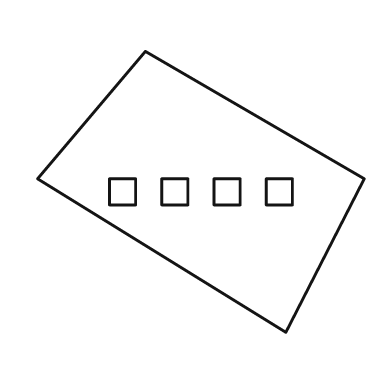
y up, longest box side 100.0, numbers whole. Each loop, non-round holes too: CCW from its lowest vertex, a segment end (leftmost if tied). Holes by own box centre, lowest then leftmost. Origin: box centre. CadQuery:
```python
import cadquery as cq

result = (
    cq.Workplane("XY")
    .moveTo(26.0, -43.0)
    .lineTo(50.0, 4.0)
    .lineTo(-17.0, 43.0)
    .lineTo(-50.0, 4.0)
    .close()
    .moveTo(-28.0, -4.0)
    .lineTo(-20.0, -4.0)
    .lineTo(-20.0, 4.0)
    .lineTo(-28.0, 4.0)
    .close()
    .moveTo(-12.0, -4.0)
    .lineTo(-4.0, -4.0)
    .lineTo(-4.0, 4.0)
    .lineTo(-12.0, 4.0)
    .close()
    .moveTo(4.0, -4.0)
    .lineTo(12.0, -4.0)
    .lineTo(12.0, 4.0)
    .lineTo(4.0, 4.0)
    .close()
    .moveTo(20.0, -4.0)
    .lineTo(28.0, -4.0)
    .lineTo(28.0, 4.0)
    .lineTo(20.0, 4.0)
    .close()
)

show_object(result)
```